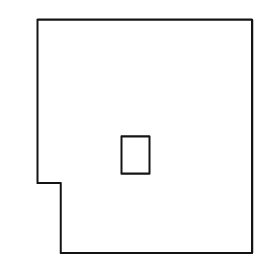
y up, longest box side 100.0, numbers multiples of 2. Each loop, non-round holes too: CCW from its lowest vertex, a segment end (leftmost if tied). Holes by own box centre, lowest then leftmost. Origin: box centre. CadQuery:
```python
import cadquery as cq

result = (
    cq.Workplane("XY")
    .moveTo(-36.0, -50.0)
    .lineTo(46.0, -50.0)
    .lineTo(46.0, 50.0)
    .lineTo(-46.0, 50.0)
    .lineTo(-46.0, -20.0)
    .lineTo(-36.0, -20.0)
    .close()
    .moveTo(-10.0, -16.0)
    .lineTo(2.0, -16.0)
    .lineTo(2.0, 0.0)
    .lineTo(-10.0, 0.0)
    .close()
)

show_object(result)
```